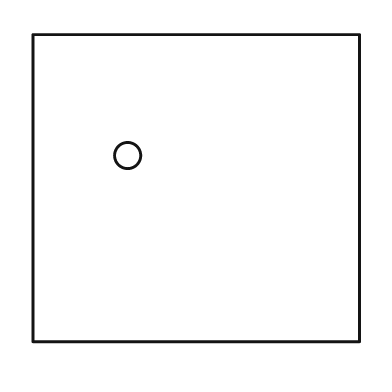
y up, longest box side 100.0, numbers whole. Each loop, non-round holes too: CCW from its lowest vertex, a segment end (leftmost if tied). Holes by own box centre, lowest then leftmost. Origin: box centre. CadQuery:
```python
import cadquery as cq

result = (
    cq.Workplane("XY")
    .moveTo(-50.0, -47.0)
    .lineTo(50.0, -47.0)
    .lineTo(50.0, 47.0)
    .lineTo(-50.0, 47.0)
    .close()
    .moveTo(-21.0, 10.0)
    .circle(4.0)
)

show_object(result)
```